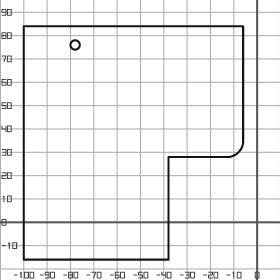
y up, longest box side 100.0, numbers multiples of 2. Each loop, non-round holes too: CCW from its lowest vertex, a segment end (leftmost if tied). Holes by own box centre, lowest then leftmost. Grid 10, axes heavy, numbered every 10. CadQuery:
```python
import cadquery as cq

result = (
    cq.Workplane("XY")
    .moveTo(-100.0, -16.0)
    .lineTo(-38.0, -16.0)
    .lineTo(-38.0, 28.0)
    .lineTo(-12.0, 28.0)
    .threePointArc((-8.0, 30.0), (-6.0, 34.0))
    .lineTo(-6.0, 84.0)
    .lineTo(-100.0, 84.0)
    .close()
    .moveTo(-78.0, 76.0)
    .circle(2.0)
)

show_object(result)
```